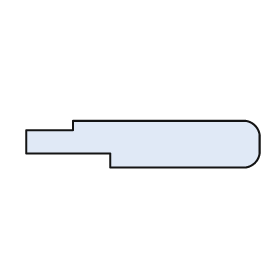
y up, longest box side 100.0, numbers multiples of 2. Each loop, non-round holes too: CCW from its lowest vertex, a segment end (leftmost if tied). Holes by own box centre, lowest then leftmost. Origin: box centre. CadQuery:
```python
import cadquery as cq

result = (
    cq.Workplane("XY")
    .moveTo(-14.0, -10.0)
    .lineTo(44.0, -10.0)
    .threePointArc((48.0, -8.0), (50.0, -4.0))
    .lineTo(50.0, 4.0)
    .threePointArc((48.0, 8.0), (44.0, 10.0))
    .lineTo(-30.0, 10.0)
    .lineTo(-30.0, 6.0)
    .lineTo(-50.0, 6.0)
    .lineTo(-50.0, -4.0)
    .lineTo(-14.0, -4.0)
    .close()
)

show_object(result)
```